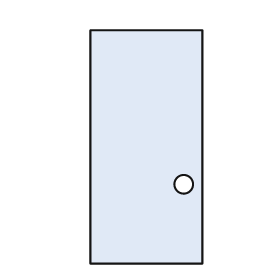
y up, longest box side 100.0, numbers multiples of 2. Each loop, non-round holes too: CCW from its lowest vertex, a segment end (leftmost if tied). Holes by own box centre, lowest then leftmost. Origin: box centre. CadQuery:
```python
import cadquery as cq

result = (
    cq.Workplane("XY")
    .moveTo(-24.0, -50.0)
    .lineTo(24.0, -50.0)
    .lineTo(24.0, 50.0)
    .lineTo(-24.0, 50.0)
    .close()
    .moveTo(16.0, -16.0)
    .circle(4.0)
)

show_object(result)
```